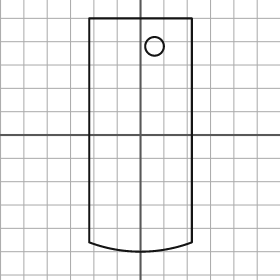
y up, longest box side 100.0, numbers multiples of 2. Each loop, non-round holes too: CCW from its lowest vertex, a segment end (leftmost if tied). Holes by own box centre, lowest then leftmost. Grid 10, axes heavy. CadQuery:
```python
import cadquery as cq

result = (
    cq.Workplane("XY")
    .moveTo(-22.0, -46.0)
    .threePointArc((0.0, -50.0), (22.0, -46.0))
    .lineTo(22.0, 50.0)
    .lineTo(-22.0, 50.0)
    .close()
    .moveTo(6.0, 38.0)
    .circle(4.0)
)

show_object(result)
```